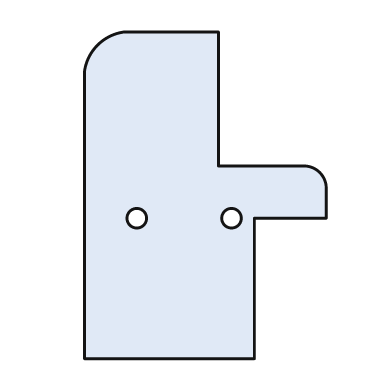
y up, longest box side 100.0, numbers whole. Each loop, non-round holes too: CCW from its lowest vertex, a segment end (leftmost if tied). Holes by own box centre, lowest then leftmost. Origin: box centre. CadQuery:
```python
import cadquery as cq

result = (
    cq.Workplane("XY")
    .moveTo(-37.0, -50.0)
    .lineTo(15.0, -50.0)
    .lineTo(15.0, -7.0)
    .lineTo(37.0, -7.0)
    .lineTo(37.0, 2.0)
    .threePointArc((35.0, 7.0), (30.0, 9.0))
    .lineTo(4.0, 9.0)
    .lineTo(4.0, 50.0)
    .lineTo(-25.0, 50.0)
    .threePointArc((-33.0, 46.0), (-37.0, 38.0))
    .close()
    .moveTo(-21.0, -7.0)
    .circle(3.0)
    .moveTo(8.0, -7.0)
    .circle(3.0)
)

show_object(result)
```